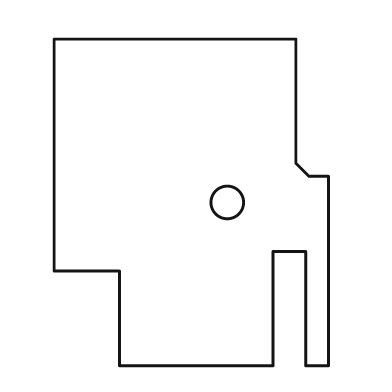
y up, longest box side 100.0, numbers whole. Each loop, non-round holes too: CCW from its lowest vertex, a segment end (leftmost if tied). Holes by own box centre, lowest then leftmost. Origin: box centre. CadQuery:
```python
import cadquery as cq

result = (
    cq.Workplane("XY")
    .moveTo(-22.0, -50.0)
    .lineTo(25.0, -50.0)
    .lineTo(25.0, -15.0)
    .lineTo(35.0, -15.0)
    .lineTo(35.0, -50.0)
    .lineTo(42.0, -50.0)
    .lineTo(42.0, 8.0)
    .lineTo(36.0, 8.0)
    .lineTo(32.0, 12.0)
    .lineTo(32.0, 50.0)
    .lineTo(-42.0, 50.0)
    .lineTo(-42.0, -21.0)
    .lineTo(-22.0, -21.0)
    .close()
    .moveTo(11.0, 0.0)
    .circle(5.0)
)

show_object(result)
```